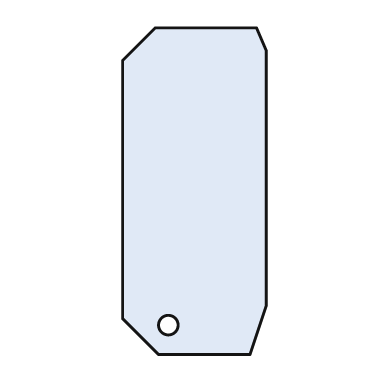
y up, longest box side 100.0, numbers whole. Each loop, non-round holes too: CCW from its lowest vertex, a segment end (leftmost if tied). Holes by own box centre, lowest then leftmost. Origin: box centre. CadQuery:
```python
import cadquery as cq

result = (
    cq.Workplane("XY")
    .moveTo(-11.0, -50.0)
    .lineTo(17.0, -50.0)
    .lineTo(22.0, -35.0)
    .lineTo(22.0, 43.0)
    .lineTo(19.0, 50.0)
    .lineTo(-12.0, 50.0)
    .lineTo(-22.0, 40.0)
    .lineTo(-22.0, -39.0)
    .close()
    .moveTo(-8.0, -41.0)
    .circle(3.0)
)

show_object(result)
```